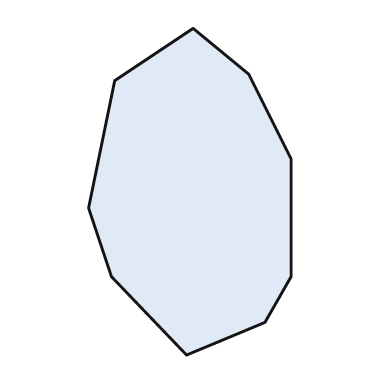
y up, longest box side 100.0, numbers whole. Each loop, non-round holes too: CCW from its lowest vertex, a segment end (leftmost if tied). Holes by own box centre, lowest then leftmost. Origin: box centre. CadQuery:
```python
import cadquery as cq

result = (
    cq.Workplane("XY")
    .moveTo(-1.0, -50.0)
    .lineTo(23.0, -40.0)
    .lineTo(31.0, -26.0)
    .lineTo(31.0, 10.0)
    .lineTo(18.0, 36.0)
    .lineTo(1.0, 50.0)
    .lineTo(-23.0, 34.0)
    .lineTo(-31.0, -5.0)
    .lineTo(-24.0, -26.0)
    .close()
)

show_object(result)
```